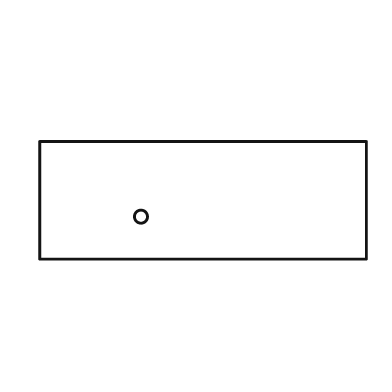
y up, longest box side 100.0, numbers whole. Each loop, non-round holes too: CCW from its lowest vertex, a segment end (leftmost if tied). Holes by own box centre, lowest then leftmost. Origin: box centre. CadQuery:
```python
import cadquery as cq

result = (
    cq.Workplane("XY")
    .moveTo(-50.0, -18.0)
    .lineTo(50.0, -18.0)
    .lineTo(50.0, 18.0)
    .lineTo(-50.0, 18.0)
    .close()
    .moveTo(-19.0, -5.0)
    .circle(2.0)
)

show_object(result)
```